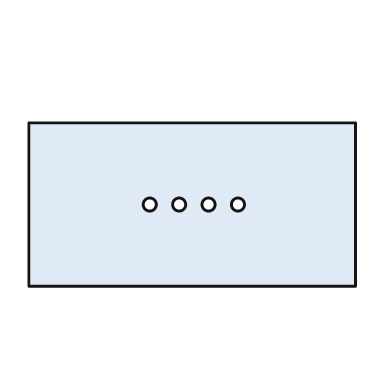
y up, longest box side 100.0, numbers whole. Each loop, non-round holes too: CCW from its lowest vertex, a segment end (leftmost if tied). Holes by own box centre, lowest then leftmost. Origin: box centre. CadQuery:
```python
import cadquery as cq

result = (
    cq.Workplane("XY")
    .moveTo(-50.0, -25.0)
    .lineTo(50.0, -25.0)
    .lineTo(50.0, 25.0)
    .lineTo(-50.0, 25.0)
    .close()
    .moveTo(-13.0, 0.0)
    .circle(2.0)
    .moveTo(-4.0, 0.0)
    .circle(2.0)
    .moveTo(5.0, 0.0)
    .circle(2.0)
    .moveTo(14.0, 0.0)
    .circle(2.0)
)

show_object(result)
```